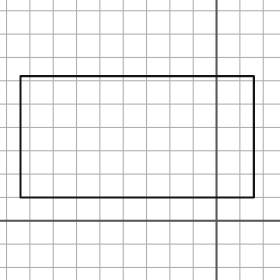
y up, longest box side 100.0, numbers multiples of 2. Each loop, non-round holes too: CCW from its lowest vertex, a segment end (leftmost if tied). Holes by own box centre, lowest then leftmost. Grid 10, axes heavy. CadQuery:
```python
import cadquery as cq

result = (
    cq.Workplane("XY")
    .moveTo(-84.0, 10.0)
    .lineTo(16.0, 10.0)
    .lineTo(16.0, 62.0)
    .lineTo(-84.0, 62.0)
    .close()
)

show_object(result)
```